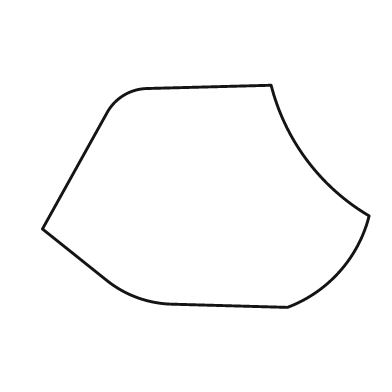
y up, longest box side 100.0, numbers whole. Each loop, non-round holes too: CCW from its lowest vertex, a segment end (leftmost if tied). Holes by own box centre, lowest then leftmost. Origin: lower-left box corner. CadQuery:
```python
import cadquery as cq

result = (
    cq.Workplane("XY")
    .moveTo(75.0, 0.0)
    .threePointArc((91.0, 11.0), (100.0, 28.0))
    .threePointArc((81.0, 45.0), (70.0, 68.0))
    .lineTo(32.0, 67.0)
    .threePointArc((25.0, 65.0), (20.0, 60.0))
    .lineTo(0.0, 24.0)
    .lineTo(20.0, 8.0)
    .threePointArc((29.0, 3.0), (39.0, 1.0))
    .close()
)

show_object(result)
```